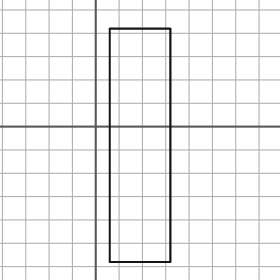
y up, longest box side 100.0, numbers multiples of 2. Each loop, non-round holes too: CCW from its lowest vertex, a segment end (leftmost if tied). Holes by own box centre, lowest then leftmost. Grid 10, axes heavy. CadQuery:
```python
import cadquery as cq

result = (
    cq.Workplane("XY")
    .moveTo(6.0, -58.0)
    .lineTo(32.0, -58.0)
    .lineTo(32.0, 42.0)
    .lineTo(6.0, 42.0)
    .close()
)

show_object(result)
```